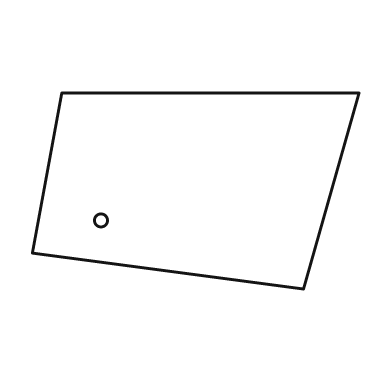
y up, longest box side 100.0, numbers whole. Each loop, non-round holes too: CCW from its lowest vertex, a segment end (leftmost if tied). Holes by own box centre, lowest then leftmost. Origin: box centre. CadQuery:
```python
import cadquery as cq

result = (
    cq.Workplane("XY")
    .moveTo(33.0, -30.0)
    .lineTo(50.0, 30.0)
    .lineTo(-41.0, 30.0)
    .lineTo(-50.0, -19.0)
    .close()
    .moveTo(-29.0, -9.0)
    .circle(2.0)
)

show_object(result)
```